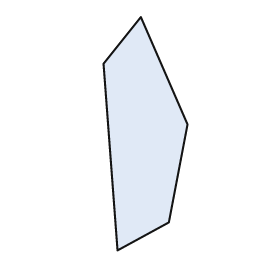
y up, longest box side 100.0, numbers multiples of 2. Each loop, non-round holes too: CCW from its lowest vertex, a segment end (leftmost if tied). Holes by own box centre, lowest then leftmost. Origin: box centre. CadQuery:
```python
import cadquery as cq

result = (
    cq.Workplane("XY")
    .moveTo(-12.0, -50.0)
    .lineTo(10.0, -38.0)
    .lineTo(18.0, 4.0)
    .lineTo(-2.0, 50.0)
    .lineTo(-18.0, 30.0)
    .close()
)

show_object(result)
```